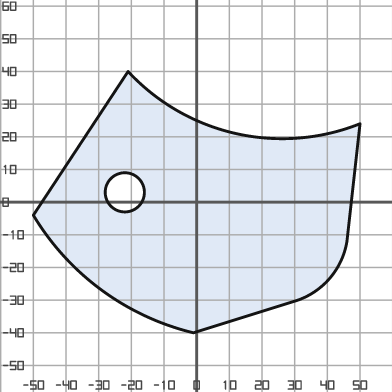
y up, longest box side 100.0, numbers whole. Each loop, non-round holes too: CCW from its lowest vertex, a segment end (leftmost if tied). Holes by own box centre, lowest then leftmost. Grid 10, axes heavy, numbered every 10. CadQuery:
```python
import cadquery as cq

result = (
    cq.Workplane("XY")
    .moveTo(-1.0, -40.0)
    .lineTo(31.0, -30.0)
    .threePointArc((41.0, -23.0), (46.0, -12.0))
    .lineTo(50.0, 24.0)
    .threePointArc((12.0, 21.0), (-21.0, 40.0))
    .lineTo(-50.0, -4.0)
    .threePointArc((-29.0, -27.0), (-1.0, -40.0))
    .close()
    .moveTo(-22.0, 3.0)
    .circle(6.0)
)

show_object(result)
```